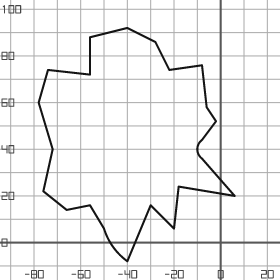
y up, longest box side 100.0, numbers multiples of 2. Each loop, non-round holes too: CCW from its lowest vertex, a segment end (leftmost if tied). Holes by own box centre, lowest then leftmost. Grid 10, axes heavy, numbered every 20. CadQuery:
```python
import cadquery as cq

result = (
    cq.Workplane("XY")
    .moveTo(-40.0, -8.0)
    .lineTo(-30.0, 16.0)
    .lineTo(-20.0, 6.0)
    .lineTo(-18.0, 24.0)
    .lineTo(6.0, 20.0)
    .lineTo(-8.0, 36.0)
    .threePointArc((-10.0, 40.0), (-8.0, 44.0))
    .lineTo(-2.0, 52.0)
    .lineTo(-6.0, 58.0)
    .lineTo(-8.0, 76.0)
    .lineTo(-22.0, 74.0)
    .lineTo(-28.0, 86.0)
    .lineTo(-40.0, 92.0)
    .lineTo(-56.0, 88.0)
    .lineTo(-56.0, 72.0)
    .lineTo(-74.0, 74.0)
    .lineTo(-78.0, 60.0)
    .lineTo(-72.0, 40.0)
    .lineTo(-76.0, 22.0)
    .lineTo(-66.0, 14.0)
    .lineTo(-56.0, 16.0)
    .lineTo(-50.0, 6.0)
    .threePointArc((-46.0, -2.0), (-40.0, -8.0))
    .close()
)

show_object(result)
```